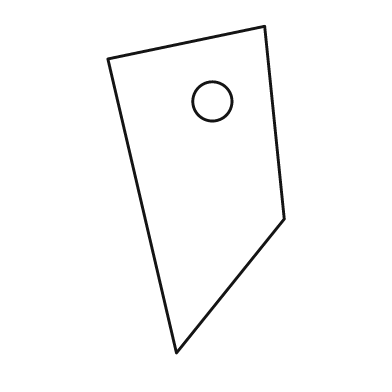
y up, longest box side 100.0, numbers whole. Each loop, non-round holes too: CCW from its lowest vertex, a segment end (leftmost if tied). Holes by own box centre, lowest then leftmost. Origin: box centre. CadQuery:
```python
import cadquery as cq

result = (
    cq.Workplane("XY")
    .moveTo(-6.0, -50.0)
    .lineTo(27.0, -9.0)
    .lineTo(21.0, 50.0)
    .lineTo(-27.0, 40.0)
    .close()
    .moveTo(5.0, 27.0)
    .circle(6.0)
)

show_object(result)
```